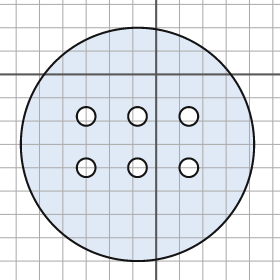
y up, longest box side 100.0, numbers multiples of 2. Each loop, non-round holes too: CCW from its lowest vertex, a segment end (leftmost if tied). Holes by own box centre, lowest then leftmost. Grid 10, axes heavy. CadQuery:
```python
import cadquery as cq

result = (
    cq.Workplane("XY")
    .moveTo(-8.0, -30.0)
    .circle(50.0)
    .moveTo(-30.0, -40.0)
    .circle(4.0)
    .moveTo(-8.0, -40.0)
    .circle(4.0)
    .moveTo(14.0, -40.0)
    .circle(4.0)
    .moveTo(-30.0, -18.0)
    .circle(4.0)
    .moveTo(-8.0, -18.0)
    .circle(4.0)
    .moveTo(14.0, -18.0)
    .circle(4.0)
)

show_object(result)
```